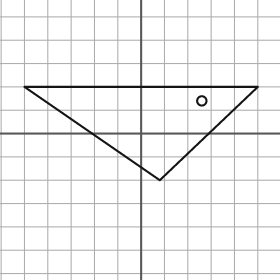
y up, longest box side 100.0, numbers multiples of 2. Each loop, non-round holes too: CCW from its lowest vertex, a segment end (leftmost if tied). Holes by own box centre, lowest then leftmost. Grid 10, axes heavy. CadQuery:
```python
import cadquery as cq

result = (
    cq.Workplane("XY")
    .moveTo(8.0, -20.0)
    .lineTo(50.0, 20.0)
    .lineTo(-50.0, 20.0)
    .close()
    .moveTo(26.0, 14.0)
    .circle(2.0)
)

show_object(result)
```